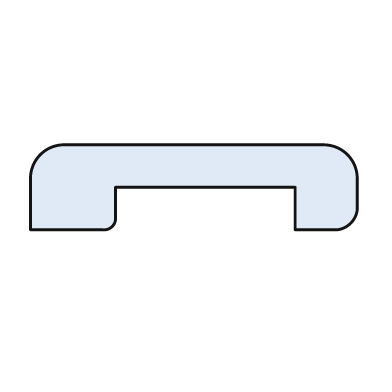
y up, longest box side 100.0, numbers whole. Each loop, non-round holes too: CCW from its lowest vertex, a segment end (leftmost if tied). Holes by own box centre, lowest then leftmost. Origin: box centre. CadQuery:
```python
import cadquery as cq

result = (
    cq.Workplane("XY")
    .moveTo(-50.0, -13.0)
    .lineTo(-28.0, -13.0)
    .threePointArc((-25.0, -12.0), (-24.0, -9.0))
    .lineTo(-24.0, 0.0)
    .lineTo(31.0, 0.0)
    .lineTo(31.0, -13.0)
    .lineTo(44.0, -13.0)
    .threePointArc((48.0, -11.0), (50.0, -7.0))
    .lineTo(50.0, 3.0)
    .threePointArc((47.0, 10.0), (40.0, 13.0))
    .lineTo(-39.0, 13.0)
    .threePointArc((-47.0, 10.0), (-50.0, 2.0))
    .close()
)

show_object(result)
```